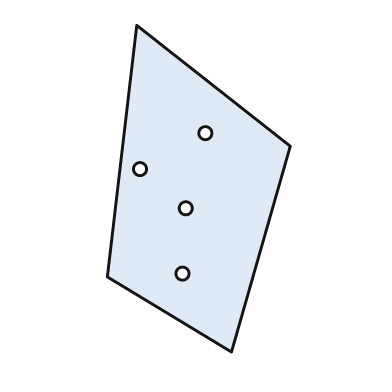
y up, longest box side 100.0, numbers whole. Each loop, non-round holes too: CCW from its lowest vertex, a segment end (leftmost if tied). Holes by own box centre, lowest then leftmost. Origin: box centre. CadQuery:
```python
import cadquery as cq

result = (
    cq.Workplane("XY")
    .moveTo(10.0, -50.0)
    .lineTo(28.0, 13.0)
    .lineTo(-19.0, 50.0)
    .lineTo(-28.0, -27.0)
    .close()
    .moveTo(-5.0, -26.0)
    .circle(2.0)
    .moveTo(-4.0, -6.0)
    .circle(2.0)
    .moveTo(-18.0, 6.0)
    .circle(2.0)
    .moveTo(2.0, 17.0)
    .circle(2.0)
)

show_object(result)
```